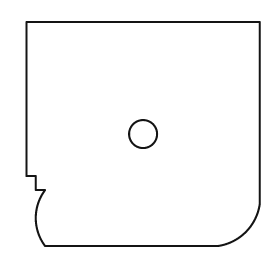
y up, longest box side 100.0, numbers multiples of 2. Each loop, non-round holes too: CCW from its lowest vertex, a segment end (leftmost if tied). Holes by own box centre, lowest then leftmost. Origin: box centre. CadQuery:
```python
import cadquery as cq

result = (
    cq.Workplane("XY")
    .moveTo(-42.0, -48.0)
    .lineTo(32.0, -48.0)
    .threePointArc((44.0, -42.0), (50.0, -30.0))
    .lineTo(50.0, 48.0)
    .lineTo(-50.0, 48.0)
    .lineTo(-50.0, -18.0)
    .lineTo(-46.0, -18.0)
    .lineTo(-46.0, -24.0)
    .lineTo(-42.0, -24.0)
    .threePointArc((-46.0, -36.0), (-42.0, -48.0))
    .close()
    .moveTo(0.0, 0.0)
    .circle(6.0)
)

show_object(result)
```